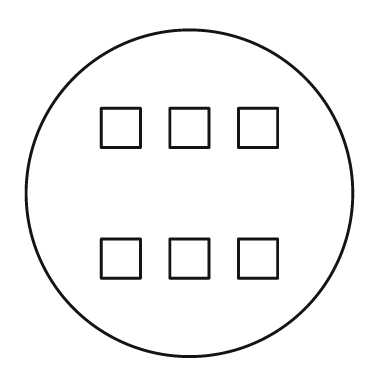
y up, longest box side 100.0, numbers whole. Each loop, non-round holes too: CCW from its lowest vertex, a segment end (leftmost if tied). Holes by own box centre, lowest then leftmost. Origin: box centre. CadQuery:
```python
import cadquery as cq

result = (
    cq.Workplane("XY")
    .moveTo(0.0, 0.0)
    .circle(50.0)
    .moveTo(-27.0, -26.0)
    .lineTo(-15.0, -26.0)
    .lineTo(-15.0, -14.0)
    .lineTo(-27.0, -14.0)
    .close()
    .moveTo(-6.0, -26.0)
    .lineTo(6.0, -26.0)
    .lineTo(6.0, -14.0)
    .lineTo(-6.0, -14.0)
    .close()
    .moveTo(15.0, -26.0)
    .lineTo(27.0, -26.0)
    .lineTo(27.0, -14.0)
    .lineTo(15.0, -14.0)
    .close()
    .moveTo(-27.0, 14.0)
    .lineTo(-15.0, 14.0)
    .lineTo(-15.0, 26.0)
    .lineTo(-27.0, 26.0)
    .close()
    .moveTo(-6.0, 14.0)
    .lineTo(6.0, 14.0)
    .lineTo(6.0, 26.0)
    .lineTo(-6.0, 26.0)
    .close()
    .moveTo(15.0, 14.0)
    .lineTo(27.0, 14.0)
    .lineTo(27.0, 26.0)
    .lineTo(15.0, 26.0)
    .close()
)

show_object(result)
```